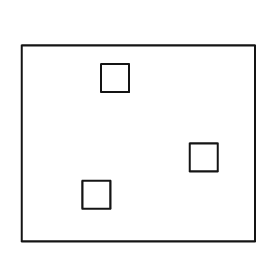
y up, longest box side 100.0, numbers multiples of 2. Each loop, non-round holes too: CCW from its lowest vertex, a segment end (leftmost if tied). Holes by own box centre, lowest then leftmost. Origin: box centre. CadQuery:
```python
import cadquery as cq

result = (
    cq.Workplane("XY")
    .moveTo(-50.0, -42.0)
    .lineTo(50.0, -42.0)
    .lineTo(50.0, 42.0)
    .lineTo(-50.0, 42.0)
    .close()
    .moveTo(-24.0, -28.0)
    .lineTo(-12.0, -28.0)
    .lineTo(-12.0, -16.0)
    .lineTo(-24.0, -16.0)
    .close()
    .moveTo(22.0, -12.0)
    .lineTo(34.0, -12.0)
    .lineTo(34.0, 0.0)
    .lineTo(22.0, 0.0)
    .close()
    .moveTo(-16.0, 22.0)
    .lineTo(-4.0, 22.0)
    .lineTo(-4.0, 34.0)
    .lineTo(-16.0, 34.0)
    .close()
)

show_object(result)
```